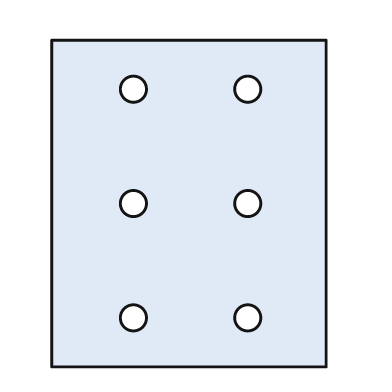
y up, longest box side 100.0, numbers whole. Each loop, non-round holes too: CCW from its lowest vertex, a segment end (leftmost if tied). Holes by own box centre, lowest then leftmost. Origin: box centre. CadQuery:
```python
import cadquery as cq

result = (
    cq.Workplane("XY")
    .moveTo(-42.0, -50.0)
    .lineTo(42.0, -50.0)
    .lineTo(42.0, 50.0)
    .lineTo(-42.0, 50.0)
    .close()
    .moveTo(-17.0, -35.0)
    .circle(4.0)
    .moveTo(18.0, -35.0)
    .circle(4.0)
    .moveTo(-17.0, 0.0)
    .circle(4.0)
    .moveTo(18.0, 0.0)
    .circle(4.0)
    .moveTo(-17.0, 35.0)
    .circle(4.0)
    .moveTo(18.0, 35.0)
    .circle(4.0)
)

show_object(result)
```